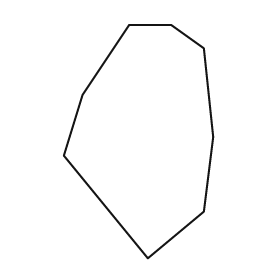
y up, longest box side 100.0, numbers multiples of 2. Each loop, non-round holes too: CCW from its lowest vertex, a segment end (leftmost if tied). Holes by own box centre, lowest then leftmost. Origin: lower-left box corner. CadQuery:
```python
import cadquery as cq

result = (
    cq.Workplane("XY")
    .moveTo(36.0, 0.0)
    .lineTo(60.0, 20.0)
    .lineTo(64.0, 52.0)
    .lineTo(60.0, 90.0)
    .lineTo(46.0, 100.0)
    .lineTo(28.0, 100.0)
    .lineTo(8.0, 70.0)
    .lineTo(0.0, 44.0)
    .close()
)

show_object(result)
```